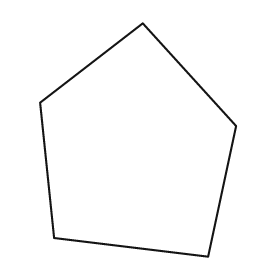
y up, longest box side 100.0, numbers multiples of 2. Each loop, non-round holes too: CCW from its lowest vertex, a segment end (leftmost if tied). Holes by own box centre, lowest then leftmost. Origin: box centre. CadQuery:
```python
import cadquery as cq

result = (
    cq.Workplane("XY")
    .moveTo(30.0, -50.0)
    .lineTo(42.0, 6.0)
    .lineTo(2.0, 50.0)
    .lineTo(-42.0, 16.0)
    .lineTo(-36.0, -42.0)
    .close()
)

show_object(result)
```